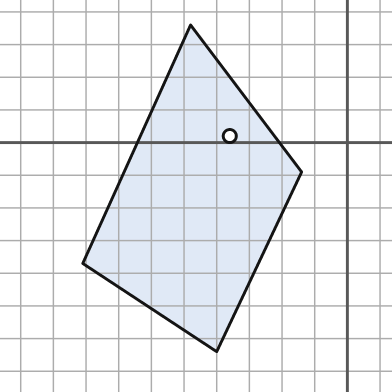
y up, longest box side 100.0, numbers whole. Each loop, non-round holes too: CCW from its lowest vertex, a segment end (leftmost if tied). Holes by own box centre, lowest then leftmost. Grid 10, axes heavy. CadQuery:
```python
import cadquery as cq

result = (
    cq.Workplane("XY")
    .moveTo(-40.0, -64.0)
    .lineTo(-14.0, -9.0)
    .lineTo(-48.0, 36.0)
    .lineTo(-81.0, -37.0)
    .close()
    .moveTo(-36.0, 2.0)
    .circle(2.0)
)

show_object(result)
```